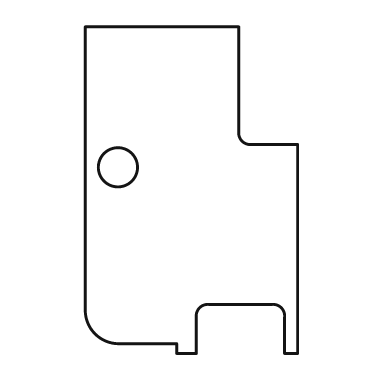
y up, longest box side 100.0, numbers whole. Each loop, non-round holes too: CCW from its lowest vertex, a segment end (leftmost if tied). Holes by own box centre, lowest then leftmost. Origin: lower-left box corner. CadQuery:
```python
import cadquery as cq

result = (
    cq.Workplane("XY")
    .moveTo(28.0, 0.0)
    .lineTo(34.0, 0.0)
    .lineTo(34.0, 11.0)
    .threePointArc((35.0, 14.0), (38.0, 15.0))
    .lineTo(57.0, 15.0)
    .threePointArc((60.0, 14.0), (61.0, 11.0))
    .lineTo(61.0, 0.0)
    .lineTo(65.0, 0.0)
    .lineTo(65.0, 64.0)
    .lineTo(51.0, 64.0)
    .threePointArc((48.0, 65.0), (47.0, 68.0))
    .lineTo(47.0, 100.0)
    .lineTo(0.0, 100.0)
    .lineTo(0.0, 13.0)
    .threePointArc((3.0, 6.0), (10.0, 3.0))
    .lineTo(28.0, 3.0)
    .close()
    .moveTo(10.0, 57.0)
    .circle(6.0)
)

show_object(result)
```